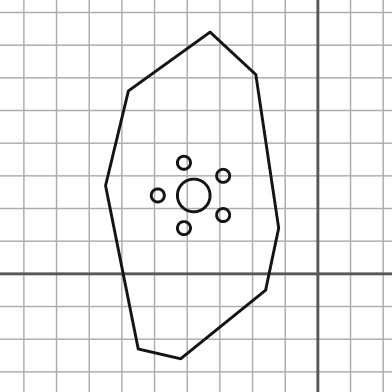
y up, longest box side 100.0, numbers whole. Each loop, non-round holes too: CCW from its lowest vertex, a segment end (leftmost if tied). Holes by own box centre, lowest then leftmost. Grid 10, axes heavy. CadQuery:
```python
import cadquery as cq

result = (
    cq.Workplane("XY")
    .moveTo(-42.0, -26.0)
    .lineTo(-16.0, -5.0)
    .lineTo(-12.0, 14.0)
    .lineTo(-19.0, 61.0)
    .lineTo(-33.0, 74.0)
    .lineTo(-58.0, 56.0)
    .lineTo(-65.0, 27.0)
    .lineTo(-55.0, -23.0)
    .close()
    .moveTo(-41.0, 14.0)
    .circle(2.0)
    .moveTo(-29.0, 18.0)
    .circle(2.0)
    .moveTo(-49.0, 24.0)
    .circle(2.0)
    .moveTo(-38.0, 24.0)
    .circle(5.0)
    .moveTo(-29.0, 30.0)
    .circle(2.0)
    .moveTo(-41.0, 34.0)
    .circle(2.0)
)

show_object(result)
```